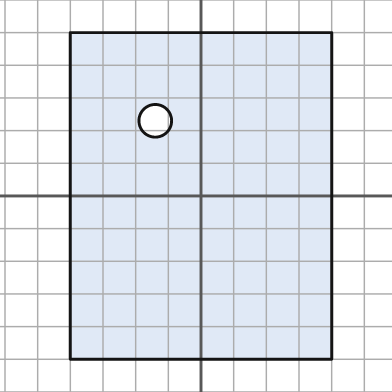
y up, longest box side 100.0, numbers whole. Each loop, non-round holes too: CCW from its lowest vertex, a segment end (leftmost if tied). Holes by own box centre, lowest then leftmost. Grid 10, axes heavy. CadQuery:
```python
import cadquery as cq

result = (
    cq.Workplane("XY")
    .moveTo(-40.0, -50.0)
    .lineTo(40.0, -50.0)
    .lineTo(40.0, 50.0)
    .lineTo(-40.0, 50.0)
    .close()
    .moveTo(-14.0, 23.0)
    .circle(5.0)
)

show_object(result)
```